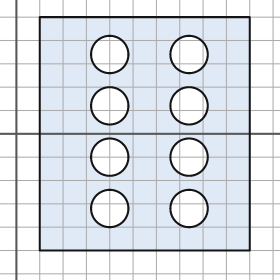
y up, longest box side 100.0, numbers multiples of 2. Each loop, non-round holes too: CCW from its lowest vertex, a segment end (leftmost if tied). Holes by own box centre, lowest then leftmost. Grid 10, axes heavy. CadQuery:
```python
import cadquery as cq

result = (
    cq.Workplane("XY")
    .moveTo(10.0, -50.0)
    .lineTo(100.0, -50.0)
    .lineTo(100.0, 50.0)
    .lineTo(10.0, 50.0)
    .close()
    .moveTo(40.0, -32.0)
    .circle(8.0)
    .moveTo(74.0, -32.0)
    .circle(8.0)
    .moveTo(40.0, -10.0)
    .circle(8.0)
    .moveTo(74.0, -10.0)
    .circle(8.0)
    .moveTo(40.0, 12.0)
    .circle(8.0)
    .moveTo(74.0, 12.0)
    .circle(8.0)
    .moveTo(40.0, 34.0)
    .circle(8.0)
    .moveTo(74.0, 34.0)
    .circle(8.0)
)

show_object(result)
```